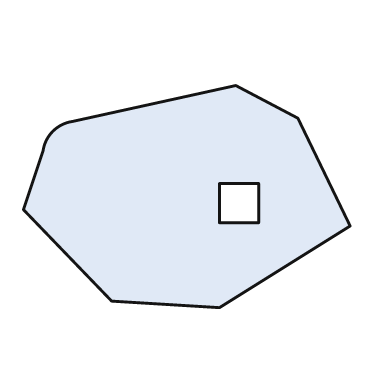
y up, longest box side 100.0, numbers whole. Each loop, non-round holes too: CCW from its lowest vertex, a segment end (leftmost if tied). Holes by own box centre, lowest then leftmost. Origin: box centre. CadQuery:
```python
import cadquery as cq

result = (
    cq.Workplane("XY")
    .moveTo(10.0, -34.0)
    .lineTo(50.0, -9.0)
    .lineTo(34.0, 24.0)
    .lineTo(15.0, 34.0)
    .lineTo(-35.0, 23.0)
    .threePointArc((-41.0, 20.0), (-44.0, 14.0))
    .lineTo(-50.0, -4.0)
    .lineTo(-23.0, -32.0)
    .close()
    .moveTo(10.0, -8.0)
    .lineTo(22.0, -8.0)
    .lineTo(22.0, 4.0)
    .lineTo(10.0, 4.0)
    .close()
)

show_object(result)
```